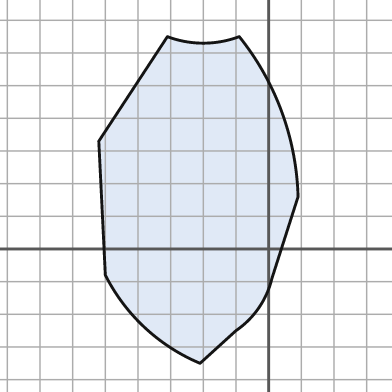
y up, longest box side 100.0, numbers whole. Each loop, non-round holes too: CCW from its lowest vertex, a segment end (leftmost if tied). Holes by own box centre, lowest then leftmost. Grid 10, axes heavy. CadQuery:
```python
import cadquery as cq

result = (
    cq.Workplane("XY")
    .moveTo(-21.0, -35.0)
    .lineTo(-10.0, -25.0)
    .threePointArc((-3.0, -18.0), (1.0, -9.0))
    .lineTo(9.0, 16.0)
    .threePointArc((4.0, 42.0), (-9.0, 65.0))
    .threePointArc((-20.0, 63.0), (-31.0, 65.0))
    .lineTo(-52.0, 33.0)
    .lineTo(-50.0, -8.0)
    .threePointArc((-38.0, -24.0), (-21.0, -35.0))
    .close()
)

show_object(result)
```